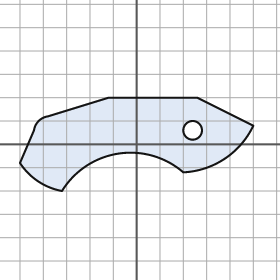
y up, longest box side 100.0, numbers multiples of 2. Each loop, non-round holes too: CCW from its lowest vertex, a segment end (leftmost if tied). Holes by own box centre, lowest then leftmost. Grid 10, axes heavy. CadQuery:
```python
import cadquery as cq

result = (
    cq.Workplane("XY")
    .moveTo(-32.0, -20.0)
    .threePointArc((-8.0, -4.0), (20.0, -12.0))
    .threePointArc((38.0, -6.0), (50.0, 8.0))
    .lineTo(26.0, 20.0)
    .lineTo(-12.0, 20.0)
    .lineTo(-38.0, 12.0)
    .threePointArc((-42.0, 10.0), (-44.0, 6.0))
    .lineTo(-50.0, -8.0)
    .threePointArc((-42.0, -16.0), (-32.0, -20.0))
    .close()
    .moveTo(24.0, 6.0)
    .circle(4.0)
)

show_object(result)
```